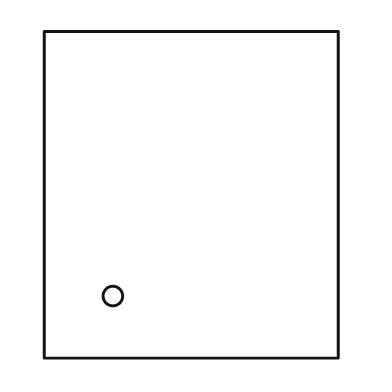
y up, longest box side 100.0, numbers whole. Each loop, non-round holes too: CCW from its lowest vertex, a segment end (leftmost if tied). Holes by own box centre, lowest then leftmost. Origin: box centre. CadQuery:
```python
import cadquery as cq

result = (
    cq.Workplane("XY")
    .moveTo(-45.0, -50.0)
    .lineTo(45.0, -50.0)
    .lineTo(45.0, 50.0)
    .lineTo(-45.0, 50.0)
    .close()
    .moveTo(-24.0, -31.0)
    .circle(3.0)
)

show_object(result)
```